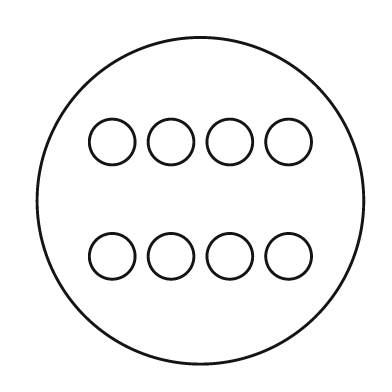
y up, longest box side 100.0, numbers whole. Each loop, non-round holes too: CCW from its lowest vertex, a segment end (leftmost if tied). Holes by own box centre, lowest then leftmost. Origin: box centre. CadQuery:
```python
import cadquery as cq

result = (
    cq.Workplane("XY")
    .moveTo(0.0, 0.0)
    .circle(50.0)
    .moveTo(-27.0, -17.0)
    .circle(7.0)
    .moveTo(-9.0, -17.0)
    .circle(7.0)
    .moveTo(9.0, -17.0)
    .circle(7.0)
    .moveTo(27.0, -17.0)
    .circle(7.0)
    .moveTo(-27.0, 18.0)
    .circle(7.0)
    .moveTo(-9.0, 18.0)
    .circle(7.0)
    .moveTo(9.0, 18.0)
    .circle(7.0)
    .moveTo(27.0, 18.0)
    .circle(7.0)
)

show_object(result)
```